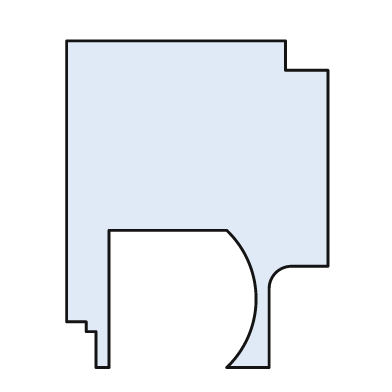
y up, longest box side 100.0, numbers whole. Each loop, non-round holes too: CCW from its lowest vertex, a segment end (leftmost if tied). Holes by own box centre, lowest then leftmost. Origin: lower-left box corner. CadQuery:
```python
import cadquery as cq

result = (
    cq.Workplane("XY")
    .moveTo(9.0, 0.0)
    .lineTo(13.0, 0.0)
    .lineTo(13.0, 42.0)
    .lineTo(49.0, 42.0)
    .threePointArc((58.0, 21.0), (49.0, 0.0))
    .lineTo(62.0, 0.0)
    .lineTo(62.0, 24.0)
    .threePointArc((64.0, 29.0), (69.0, 31.0))
    .lineTo(80.0, 31.0)
    .lineTo(80.0, 91.0)
    .lineTo(67.0, 91.0)
    .lineTo(67.0, 100.0)
    .lineTo(0.0, 100.0)
    .lineTo(0.0, 14.0)
    .lineTo(6.0, 14.0)
    .lineTo(6.0, 11.0)
    .lineTo(9.0, 11.0)
    .close()
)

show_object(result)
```